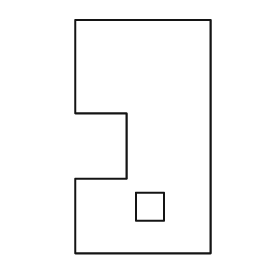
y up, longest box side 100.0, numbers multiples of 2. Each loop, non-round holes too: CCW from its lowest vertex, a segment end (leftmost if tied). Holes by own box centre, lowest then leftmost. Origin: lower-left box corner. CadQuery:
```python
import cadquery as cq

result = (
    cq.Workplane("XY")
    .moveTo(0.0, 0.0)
    .lineTo(58.0, 0.0)
    .lineTo(58.0, 100.0)
    .lineTo(0.0, 100.0)
    .lineTo(0.0, 60.0)
    .lineTo(22.0, 60.0)
    .lineTo(22.0, 32.0)
    .lineTo(0.0, 32.0)
    .close()
    .moveTo(26.0, 14.0)
    .lineTo(38.0, 14.0)
    .lineTo(38.0, 26.0)
    .lineTo(26.0, 26.0)
    .close()
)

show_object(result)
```